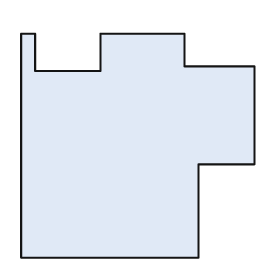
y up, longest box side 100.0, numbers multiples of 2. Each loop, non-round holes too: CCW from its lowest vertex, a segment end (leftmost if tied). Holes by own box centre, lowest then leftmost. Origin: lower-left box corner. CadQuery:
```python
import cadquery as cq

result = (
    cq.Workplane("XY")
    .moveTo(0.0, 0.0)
    .lineTo(76.0, 0.0)
    .lineTo(76.0, 40.0)
    .lineTo(100.0, 40.0)
    .lineTo(100.0, 82.0)
    .lineTo(70.0, 82.0)
    .lineTo(70.0, 96.0)
    .lineTo(34.0, 96.0)
    .lineTo(34.0, 80.0)
    .lineTo(6.0, 80.0)
    .lineTo(6.0, 96.0)
    .lineTo(0.0, 96.0)
    .close()
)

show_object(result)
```